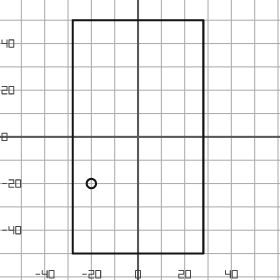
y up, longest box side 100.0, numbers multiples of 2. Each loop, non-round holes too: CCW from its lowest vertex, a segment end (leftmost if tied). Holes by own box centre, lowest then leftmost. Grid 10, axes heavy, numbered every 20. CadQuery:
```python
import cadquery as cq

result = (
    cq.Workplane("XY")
    .moveTo(-28.0, -50.0)
    .lineTo(28.0, -50.0)
    .lineTo(28.0, 50.0)
    .lineTo(-28.0, 50.0)
    .close()
    .moveTo(-20.0, -20.0)
    .circle(2.0)
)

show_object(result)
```